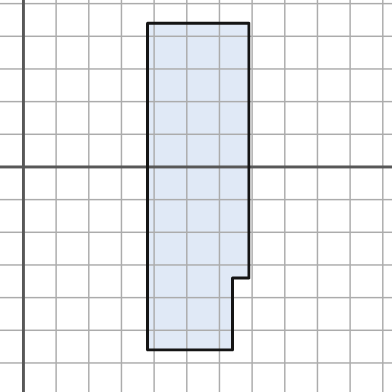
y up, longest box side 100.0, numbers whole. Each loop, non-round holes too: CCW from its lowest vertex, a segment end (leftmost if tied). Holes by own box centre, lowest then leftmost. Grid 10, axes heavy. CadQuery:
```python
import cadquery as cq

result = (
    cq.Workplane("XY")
    .moveTo(38.0, -56.0)
    .lineTo(64.0, -56.0)
    .lineTo(64.0, -34.0)
    .lineTo(69.0, -34.0)
    .lineTo(69.0, 44.0)
    .lineTo(38.0, 44.0)
    .close()
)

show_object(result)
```